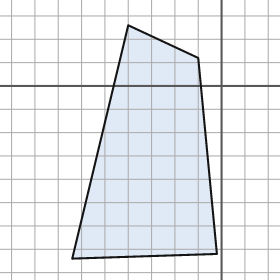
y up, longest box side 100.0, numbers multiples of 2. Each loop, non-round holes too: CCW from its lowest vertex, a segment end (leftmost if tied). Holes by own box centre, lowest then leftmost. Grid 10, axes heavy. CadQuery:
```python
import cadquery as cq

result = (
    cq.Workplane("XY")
    .moveTo(-64.0, -74.0)
    .lineTo(-2.0, -72.0)
    .lineTo(-10.0, 12.0)
    .lineTo(-40.0, 26.0)
    .close()
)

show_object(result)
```